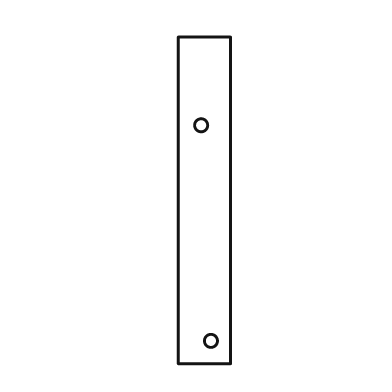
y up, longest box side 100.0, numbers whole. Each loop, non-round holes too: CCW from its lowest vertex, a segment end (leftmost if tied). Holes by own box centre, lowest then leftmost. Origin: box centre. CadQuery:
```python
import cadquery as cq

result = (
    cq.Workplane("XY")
    .moveTo(-8.0, -50.0)
    .lineTo(8.0, -50.0)
    .lineTo(8.0, 50.0)
    .lineTo(-8.0, 50.0)
    .close()
    .moveTo(2.0, -43.0)
    .circle(2.0)
    .moveTo(-1.0, 23.0)
    .circle(2.0)
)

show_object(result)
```